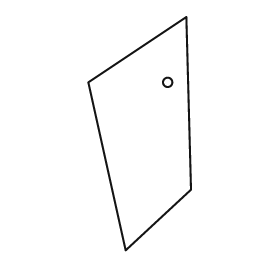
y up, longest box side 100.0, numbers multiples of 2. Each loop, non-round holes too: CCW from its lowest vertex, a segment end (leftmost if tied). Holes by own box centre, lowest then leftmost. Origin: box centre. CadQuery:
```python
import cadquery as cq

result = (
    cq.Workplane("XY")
    .moveTo(-6.0, -50.0)
    .lineTo(22.0, -24.0)
    .lineTo(20.0, 50.0)
    .lineTo(-22.0, 22.0)
    .close()
    .moveTo(12.0, 22.0)
    .circle(2.0)
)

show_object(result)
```